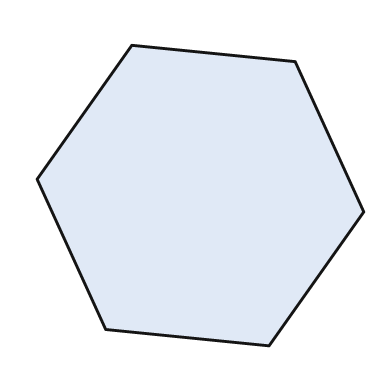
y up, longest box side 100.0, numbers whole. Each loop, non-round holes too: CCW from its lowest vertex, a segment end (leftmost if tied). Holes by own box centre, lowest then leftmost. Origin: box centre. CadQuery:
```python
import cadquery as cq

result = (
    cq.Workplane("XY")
    .moveTo(21.0, -46.0)
    .lineTo(50.0, -5.0)
    .lineTo(29.0, 41.0)
    .lineTo(-21.0, 46.0)
    .lineTo(-50.0, 5.0)
    .lineTo(-29.0, -41.0)
    .close()
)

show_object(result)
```